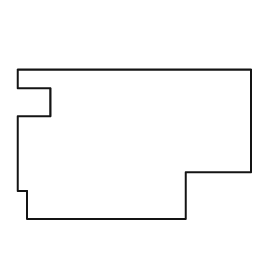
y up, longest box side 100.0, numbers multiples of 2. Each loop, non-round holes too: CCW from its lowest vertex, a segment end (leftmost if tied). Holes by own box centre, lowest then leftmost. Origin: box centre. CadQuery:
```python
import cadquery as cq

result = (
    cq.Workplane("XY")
    .moveTo(-46.0, -32.0)
    .lineTo(22.0, -32.0)
    .lineTo(22.0, -12.0)
    .lineTo(50.0, -12.0)
    .lineTo(50.0, 32.0)
    .lineTo(-50.0, 32.0)
    .lineTo(-50.0, 24.0)
    .lineTo(-36.0, 24.0)
    .lineTo(-36.0, 12.0)
    .lineTo(-50.0, 12.0)
    .lineTo(-50.0, -20.0)
    .lineTo(-46.0, -20.0)
    .close()
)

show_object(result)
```